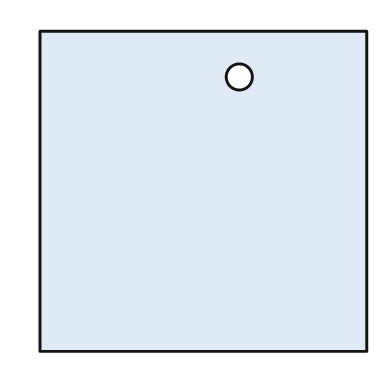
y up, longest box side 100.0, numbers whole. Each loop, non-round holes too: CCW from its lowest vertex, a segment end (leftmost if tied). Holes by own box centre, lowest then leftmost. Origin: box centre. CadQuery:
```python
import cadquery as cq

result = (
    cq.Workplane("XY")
    .moveTo(-50.0, -49.0)
    .lineTo(50.0, -49.0)
    .lineTo(50.0, 49.0)
    .lineTo(-50.0, 49.0)
    .close()
    .moveTo(11.0, 35.0)
    .circle(4.0)
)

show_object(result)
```